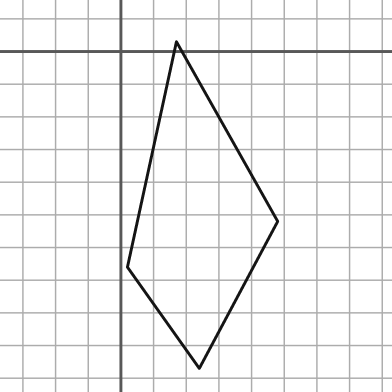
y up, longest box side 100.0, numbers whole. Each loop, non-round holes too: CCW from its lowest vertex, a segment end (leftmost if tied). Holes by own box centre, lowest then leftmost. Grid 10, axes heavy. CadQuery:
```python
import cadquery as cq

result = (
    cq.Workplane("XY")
    .moveTo(24.0, -97.0)
    .lineTo(48.0, -52.0)
    .lineTo(17.0, 3.0)
    .lineTo(2.0, -66.0)
    .close()
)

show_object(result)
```